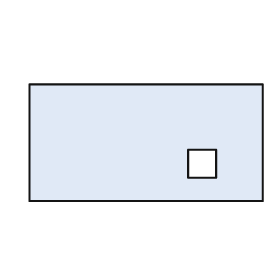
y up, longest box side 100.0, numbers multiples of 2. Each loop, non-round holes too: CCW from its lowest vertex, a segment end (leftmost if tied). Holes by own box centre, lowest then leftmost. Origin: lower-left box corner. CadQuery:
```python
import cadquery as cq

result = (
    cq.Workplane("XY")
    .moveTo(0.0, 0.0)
    .lineTo(100.0, 0.0)
    .lineTo(100.0, 50.0)
    .lineTo(0.0, 50.0)
    .close()
    .moveTo(68.0, 10.0)
    .lineTo(80.0, 10.0)
    .lineTo(80.0, 22.0)
    .lineTo(68.0, 22.0)
    .close()
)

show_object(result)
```